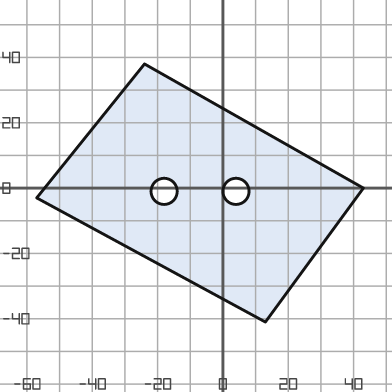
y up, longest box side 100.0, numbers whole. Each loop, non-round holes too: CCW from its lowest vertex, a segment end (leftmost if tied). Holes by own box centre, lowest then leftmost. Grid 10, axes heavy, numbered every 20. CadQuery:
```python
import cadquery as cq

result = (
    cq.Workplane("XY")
    .moveTo(13.0, -41.0)
    .lineTo(43.0, 0.0)
    .lineTo(-24.0, 38.0)
    .lineTo(-57.0, -3.0)
    .close()
    .moveTo(-18.0, -1.0)
    .circle(4.0)
    .moveTo(4.0, -1.0)
    .circle(4.0)
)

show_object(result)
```